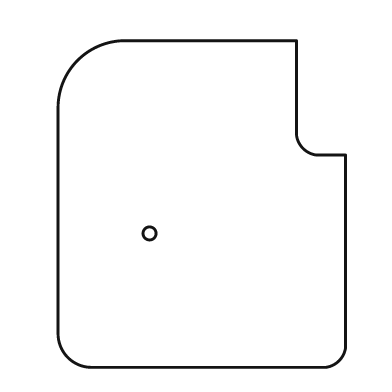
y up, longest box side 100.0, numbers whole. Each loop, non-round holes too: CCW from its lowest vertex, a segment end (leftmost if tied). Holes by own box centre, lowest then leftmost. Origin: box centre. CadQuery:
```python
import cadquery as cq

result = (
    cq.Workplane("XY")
    .moveTo(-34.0, -50.0)
    .lineTo(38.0, -50.0)
    .threePointArc((42.0, -48.0), (44.0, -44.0))
    .lineTo(44.0, 15.0)
    .lineTo(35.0, 15.0)
    .threePointArc((31.0, 17.0), (29.0, 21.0))
    .lineTo(29.0, 50.0)
    .lineTo(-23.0, 50.0)
    .threePointArc((-38.0, 44.0), (-44.0, 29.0))
    .lineTo(-44.0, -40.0)
    .threePointArc((-41.0, -47.0), (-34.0, -50.0))
    .close()
    .moveTo(-16.0, -9.0)
    .circle(2.0)
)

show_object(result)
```